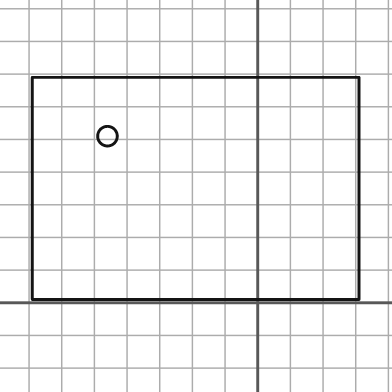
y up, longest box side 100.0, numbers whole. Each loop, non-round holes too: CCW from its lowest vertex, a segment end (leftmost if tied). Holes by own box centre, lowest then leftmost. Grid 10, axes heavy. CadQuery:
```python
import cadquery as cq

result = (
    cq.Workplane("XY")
    .moveTo(-69.0, 1.0)
    .lineTo(31.0, 1.0)
    .lineTo(31.0, 69.0)
    .lineTo(-69.0, 69.0)
    .close()
    .moveTo(-46.0, 51.0)
    .circle(3.0)
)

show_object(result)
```